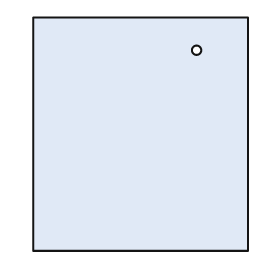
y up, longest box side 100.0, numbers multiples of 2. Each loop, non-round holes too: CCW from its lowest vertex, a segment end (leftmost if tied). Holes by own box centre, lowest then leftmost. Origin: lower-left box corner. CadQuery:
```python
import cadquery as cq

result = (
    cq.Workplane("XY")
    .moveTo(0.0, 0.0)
    .lineTo(92.0, 0.0)
    .lineTo(92.0, 100.0)
    .lineTo(0.0, 100.0)
    .close()
    .moveTo(70.0, 86.0)
    .circle(2.0)
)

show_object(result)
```